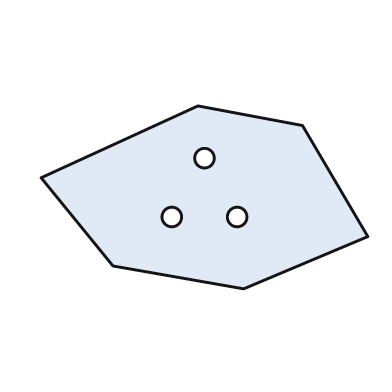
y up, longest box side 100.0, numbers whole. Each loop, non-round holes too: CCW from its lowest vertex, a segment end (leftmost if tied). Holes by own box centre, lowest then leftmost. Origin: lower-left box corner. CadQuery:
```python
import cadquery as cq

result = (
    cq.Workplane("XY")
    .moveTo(62.0, 0.0)
    .lineTo(100.0, 16.0)
    .lineTo(80.0, 50.0)
    .lineTo(48.0, 56.0)
    .lineTo(0.0, 34.0)
    .lineTo(22.0, 7.0)
    .close()
    .moveTo(40.0, 22.0)
    .circle(3.0)
    .moveTo(60.0, 22.0)
    .circle(3.0)
    .moveTo(50.0, 40.0)
    .circle(3.0)
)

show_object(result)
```